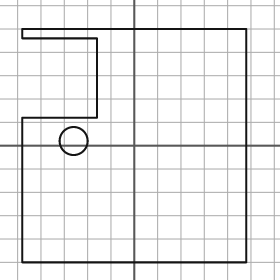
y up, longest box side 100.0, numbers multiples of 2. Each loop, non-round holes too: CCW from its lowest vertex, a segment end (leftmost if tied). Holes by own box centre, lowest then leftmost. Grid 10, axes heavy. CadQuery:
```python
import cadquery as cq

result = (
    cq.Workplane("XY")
    .moveTo(-48.0, -50.0)
    .lineTo(48.0, -50.0)
    .lineTo(48.0, 50.0)
    .lineTo(-48.0, 50.0)
    .lineTo(-48.0, 46.0)
    .lineTo(-16.0, 46.0)
    .lineTo(-16.0, 12.0)
    .lineTo(-48.0, 12.0)
    .close()
    .moveTo(-26.0, 2.0)
    .circle(6.0)
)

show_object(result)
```